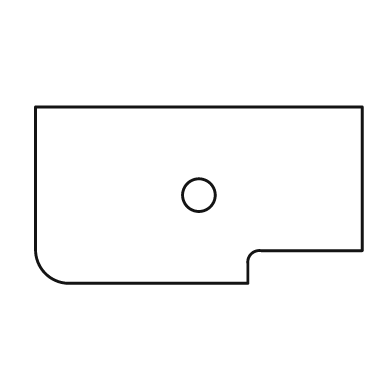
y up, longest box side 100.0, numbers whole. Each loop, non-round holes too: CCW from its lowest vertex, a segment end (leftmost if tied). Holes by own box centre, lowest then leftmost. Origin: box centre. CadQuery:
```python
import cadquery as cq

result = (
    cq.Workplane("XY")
    .moveTo(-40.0, -27.0)
    .lineTo(15.0, -27.0)
    .lineTo(15.0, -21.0)
    .threePointArc((16.0, -18.0), (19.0, -17.0))
    .lineTo(50.0, -17.0)
    .lineTo(50.0, 27.0)
    .lineTo(-50.0, 27.0)
    .lineTo(-50.0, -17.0)
    .threePointArc((-47.0, -24.0), (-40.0, -27.0))
    .close()
    .moveTo(0.0, 0.0)
    .circle(5.0)
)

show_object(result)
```